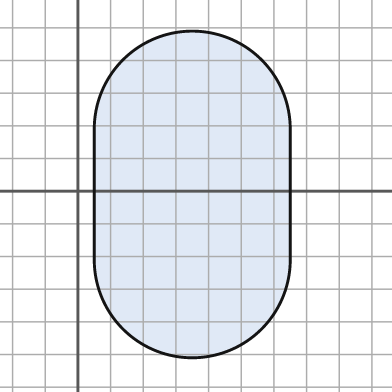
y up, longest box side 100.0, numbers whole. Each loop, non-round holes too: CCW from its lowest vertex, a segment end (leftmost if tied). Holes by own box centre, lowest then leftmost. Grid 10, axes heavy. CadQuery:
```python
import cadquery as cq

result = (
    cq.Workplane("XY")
    .moveTo(5.0, -21.0)
    .threePointArc((35.0, -51.0), (65.0, -21.0))
    .lineTo(65.0, 19.0)
    .threePointArc((35.0, 49.0), (5.0, 19.0))
    .close()
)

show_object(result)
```